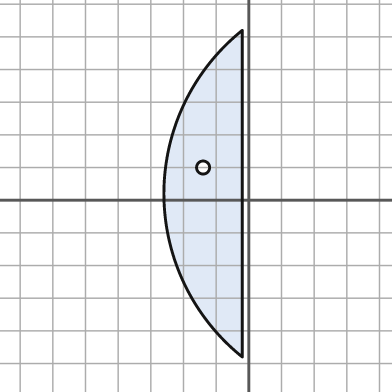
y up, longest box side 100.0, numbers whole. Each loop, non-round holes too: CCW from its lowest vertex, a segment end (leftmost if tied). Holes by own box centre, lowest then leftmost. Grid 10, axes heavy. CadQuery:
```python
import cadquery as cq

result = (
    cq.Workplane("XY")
    .moveTo(-2.0, -48.0)
    .lineTo(-2.0, 52.0)
    .threePointArc((-26.0, 2.0), (-2.0, -48.0))
    .close()
    .moveTo(-14.0, 10.0)
    .circle(2.0)
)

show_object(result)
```